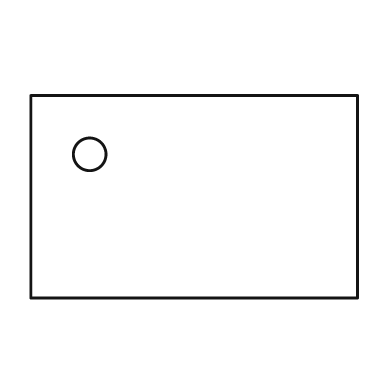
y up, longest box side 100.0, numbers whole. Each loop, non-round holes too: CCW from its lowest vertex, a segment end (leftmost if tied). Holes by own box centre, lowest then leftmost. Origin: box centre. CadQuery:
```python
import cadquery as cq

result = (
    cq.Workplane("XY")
    .moveTo(-50.0, -31.0)
    .lineTo(50.0, -31.0)
    .lineTo(50.0, 31.0)
    .lineTo(-50.0, 31.0)
    .close()
    .moveTo(-32.0, 13.0)
    .circle(5.0)
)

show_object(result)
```